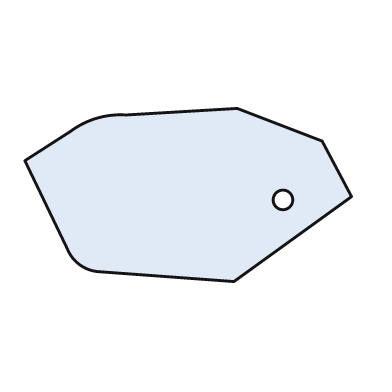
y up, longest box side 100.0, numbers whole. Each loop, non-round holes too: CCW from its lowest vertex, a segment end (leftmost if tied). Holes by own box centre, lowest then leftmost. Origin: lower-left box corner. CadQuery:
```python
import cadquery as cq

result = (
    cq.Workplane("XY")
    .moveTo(64.0, 0.0)
    .lineTo(100.0, 26.0)
    .lineTo(91.0, 43.0)
    .lineTo(65.0, 53.0)
    .lineTo(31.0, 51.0)
    .threePointArc((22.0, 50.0), (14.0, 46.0))
    .lineTo(0.0, 37.0)
    .lineTo(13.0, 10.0)
    .threePointArc((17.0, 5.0), (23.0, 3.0))
    .close()
    .moveTo(79.0, 25.0)
    .circle(3.0)
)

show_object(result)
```